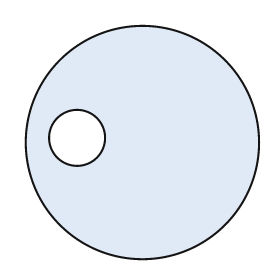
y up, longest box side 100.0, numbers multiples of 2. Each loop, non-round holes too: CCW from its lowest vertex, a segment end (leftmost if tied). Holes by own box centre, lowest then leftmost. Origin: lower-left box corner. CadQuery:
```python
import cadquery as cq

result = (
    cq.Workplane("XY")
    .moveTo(50.0, 50.0)
    .circle(50.0)
    .moveTo(22.0, 52.0)
    .circle(12.0)
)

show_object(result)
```